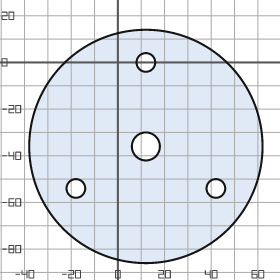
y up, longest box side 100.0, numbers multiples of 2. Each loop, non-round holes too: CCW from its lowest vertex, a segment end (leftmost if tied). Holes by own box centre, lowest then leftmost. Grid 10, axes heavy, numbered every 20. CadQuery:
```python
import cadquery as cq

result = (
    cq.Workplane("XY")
    .moveTo(12.0, -36.0)
    .circle(50.0)
    .moveTo(-18.0, -54.0)
    .circle(4.0)
    .moveTo(42.0, -54.0)
    .circle(4.0)
    .moveTo(12.0, -36.0)
    .circle(6.0)
    .moveTo(12.0, 0.0)
    .circle(4.0)
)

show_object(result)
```